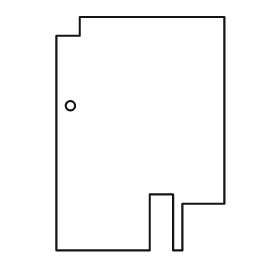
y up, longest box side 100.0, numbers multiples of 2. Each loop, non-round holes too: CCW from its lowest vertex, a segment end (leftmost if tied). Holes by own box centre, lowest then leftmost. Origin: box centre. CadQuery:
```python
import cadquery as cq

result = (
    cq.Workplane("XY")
    .moveTo(-36.0, -50.0)
    .lineTo(4.0, -50.0)
    .lineTo(4.0, -26.0)
    .lineTo(14.0, -26.0)
    .lineTo(14.0, -50.0)
    .lineTo(18.0, -50.0)
    .lineTo(18.0, -30.0)
    .lineTo(36.0, -30.0)
    .lineTo(36.0, 50.0)
    .lineTo(-26.0, 50.0)
    .lineTo(-26.0, 42.0)
    .lineTo(-36.0, 42.0)
    .close()
    .moveTo(-30.0, 12.0)
    .circle(2.0)
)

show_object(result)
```